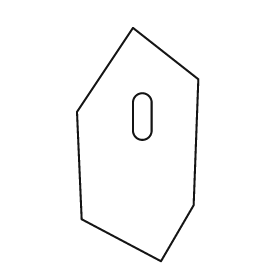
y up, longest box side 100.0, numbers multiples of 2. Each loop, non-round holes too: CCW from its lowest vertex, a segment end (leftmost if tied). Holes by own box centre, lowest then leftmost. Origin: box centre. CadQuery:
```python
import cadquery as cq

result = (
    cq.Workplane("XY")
    .moveTo(10.0, -50.0)
    .lineTo(24.0, -26.0)
    .lineTo(26.0, 28.0)
    .lineTo(-2.0, 50.0)
    .lineTo(-26.0, 14.0)
    .lineTo(-24.0, -32.0)
    .close()
    .moveTo(-2.0, 6.0)
    .threePointArc((2.0, 2.0), (6.0, 6.0))
    .lineTo(6.0, 18.0)
    .threePointArc((2.0, 22.0), (-2.0, 18.0))
    .close()
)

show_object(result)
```